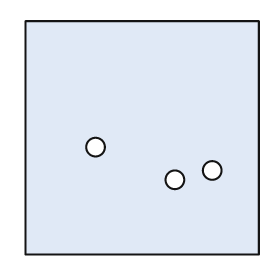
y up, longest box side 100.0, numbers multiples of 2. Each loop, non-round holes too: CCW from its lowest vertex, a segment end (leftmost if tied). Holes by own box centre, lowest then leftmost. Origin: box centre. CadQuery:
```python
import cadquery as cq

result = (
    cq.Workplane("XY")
    .moveTo(-50.0, -50.0)
    .lineTo(50.0, -50.0)
    .lineTo(50.0, 50.0)
    .lineTo(-50.0, 50.0)
    .close()
    .moveTo(14.0, -18.0)
    .circle(4.0)
    .moveTo(30.0, -14.0)
    .circle(4.0)
    .moveTo(-20.0, -4.0)
    .circle(4.0)
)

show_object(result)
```